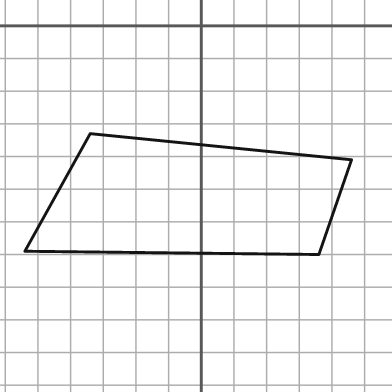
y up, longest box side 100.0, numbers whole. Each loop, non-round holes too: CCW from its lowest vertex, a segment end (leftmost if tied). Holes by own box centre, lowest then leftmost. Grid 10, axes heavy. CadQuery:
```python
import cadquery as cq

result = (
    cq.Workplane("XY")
    .moveTo(36.0, -70.0)
    .lineTo(46.0, -41.0)
    .lineTo(-34.0, -33.0)
    .lineTo(-54.0, -69.0)
    .close()
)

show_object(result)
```